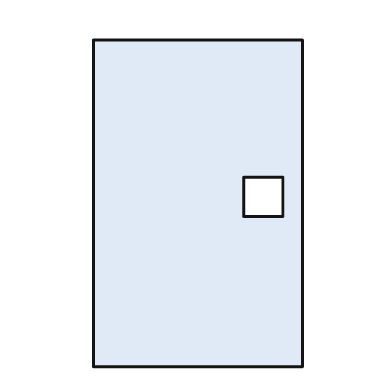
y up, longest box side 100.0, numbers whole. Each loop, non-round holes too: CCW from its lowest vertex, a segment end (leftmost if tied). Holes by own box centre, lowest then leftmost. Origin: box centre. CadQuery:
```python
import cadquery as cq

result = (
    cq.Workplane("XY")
    .moveTo(-32.0, -50.0)
    .lineTo(32.0, -50.0)
    .lineTo(32.0, 50.0)
    .lineTo(-32.0, 50.0)
    .close()
    .moveTo(14.0, -4.0)
    .lineTo(26.0, -4.0)
    .lineTo(26.0, 8.0)
    .lineTo(14.0, 8.0)
    .close()
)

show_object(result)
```